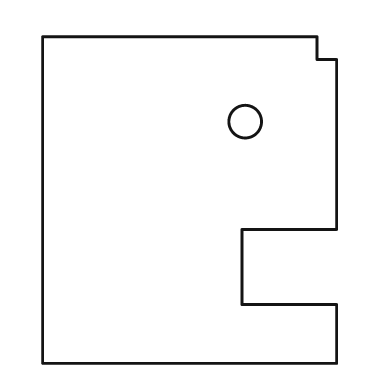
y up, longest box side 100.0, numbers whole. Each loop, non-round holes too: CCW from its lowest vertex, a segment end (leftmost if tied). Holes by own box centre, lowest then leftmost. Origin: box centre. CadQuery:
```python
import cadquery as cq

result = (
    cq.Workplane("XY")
    .moveTo(-45.0, -50.0)
    .lineTo(45.0, -50.0)
    .lineTo(45.0, -32.0)
    .lineTo(16.0, -32.0)
    .lineTo(16.0, -9.0)
    .lineTo(45.0, -9.0)
    .lineTo(45.0, 43.0)
    .lineTo(39.0, 43.0)
    .lineTo(39.0, 50.0)
    .lineTo(-45.0, 50.0)
    .close()
    .moveTo(17.0, 24.0)
    .circle(5.0)
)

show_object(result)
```